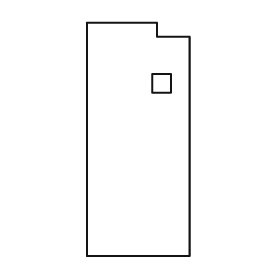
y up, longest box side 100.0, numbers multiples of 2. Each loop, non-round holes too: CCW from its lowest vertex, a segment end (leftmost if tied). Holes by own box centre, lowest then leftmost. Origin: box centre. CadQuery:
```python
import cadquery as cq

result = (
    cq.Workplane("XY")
    .moveTo(-22.0, -50.0)
    .lineTo(22.0, -50.0)
    .lineTo(22.0, 44.0)
    .lineTo(8.0, 44.0)
    .lineTo(8.0, 50.0)
    .lineTo(-22.0, 50.0)
    .close()
    .moveTo(6.0, 20.0)
    .lineTo(14.0, 20.0)
    .lineTo(14.0, 28.0)
    .lineTo(6.0, 28.0)
    .close()
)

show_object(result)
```